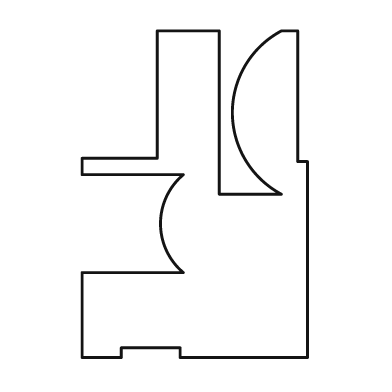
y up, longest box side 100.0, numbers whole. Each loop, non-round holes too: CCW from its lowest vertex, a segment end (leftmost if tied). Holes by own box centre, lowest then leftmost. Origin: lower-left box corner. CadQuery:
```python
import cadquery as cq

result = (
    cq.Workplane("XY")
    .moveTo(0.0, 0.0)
    .lineTo(12.0, 0.0)
    .lineTo(12.0, 3.0)
    .lineTo(30.0, 3.0)
    .lineTo(30.0, 0.0)
    .lineTo(69.0, 0.0)
    .lineTo(69.0, 60.0)
    .lineTo(66.0, 60.0)
    .lineTo(66.0, 100.0)
    .lineTo(61.0, 100.0)
    .threePointArc((46.0, 75.0), (61.0, 50.0))
    .lineTo(42.0, 50.0)
    .lineTo(42.0, 100.0)
    .lineTo(23.0, 100.0)
    .lineTo(23.0, 61.0)
    .lineTo(0.0, 61.0)
    .lineTo(0.0, 56.0)
    .lineTo(31.0, 56.0)
    .threePointArc((24.0, 41.0), (31.0, 26.0))
    .lineTo(0.0, 26.0)
    .close()
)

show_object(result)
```